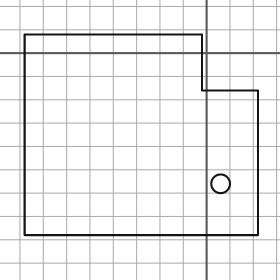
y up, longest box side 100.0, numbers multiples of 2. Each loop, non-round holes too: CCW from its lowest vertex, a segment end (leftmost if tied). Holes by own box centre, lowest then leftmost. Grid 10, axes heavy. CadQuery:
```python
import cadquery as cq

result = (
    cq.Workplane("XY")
    .moveTo(-78.0, -78.0)
    .lineTo(22.0, -78.0)
    .lineTo(22.0, -16.0)
    .lineTo(-2.0, -16.0)
    .lineTo(-2.0, 8.0)
    .lineTo(-78.0, 8.0)
    .close()
    .moveTo(6.0, -56.0)
    .circle(4.0)
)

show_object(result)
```